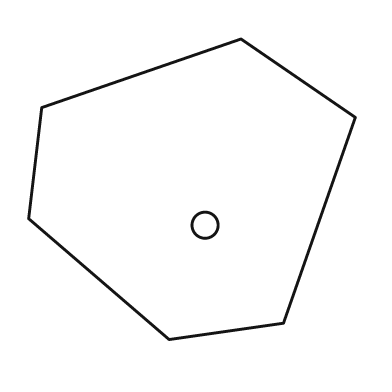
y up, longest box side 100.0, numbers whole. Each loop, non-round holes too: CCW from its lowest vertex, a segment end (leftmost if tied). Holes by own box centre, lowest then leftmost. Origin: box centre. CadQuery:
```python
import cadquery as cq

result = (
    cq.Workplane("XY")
    .moveTo(-7.0, -46.0)
    .lineTo(28.0, -41.0)
    .lineTo(50.0, 22.0)
    .lineTo(15.0, 46.0)
    .lineTo(-46.0, 25.0)
    .lineTo(-50.0, -9.0)
    .close()
    .moveTo(4.0, -11.0)
    .circle(4.0)
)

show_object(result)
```